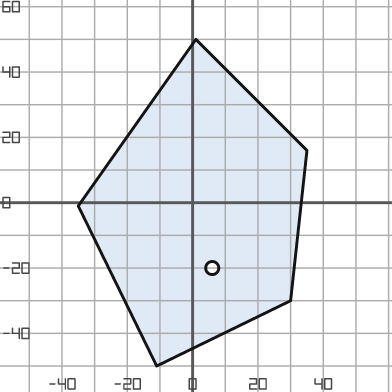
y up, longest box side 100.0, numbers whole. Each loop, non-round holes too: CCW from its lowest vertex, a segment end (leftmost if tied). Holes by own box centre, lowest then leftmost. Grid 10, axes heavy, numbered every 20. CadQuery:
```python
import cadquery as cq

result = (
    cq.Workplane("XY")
    .moveTo(-11.0, -50.0)
    .lineTo(30.0, -30.0)
    .lineTo(35.0, 16.0)
    .lineTo(1.0, 50.0)
    .lineTo(-35.0, -1.0)
    .close()
    .moveTo(6.0, -20.0)
    .circle(2.0)
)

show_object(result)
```